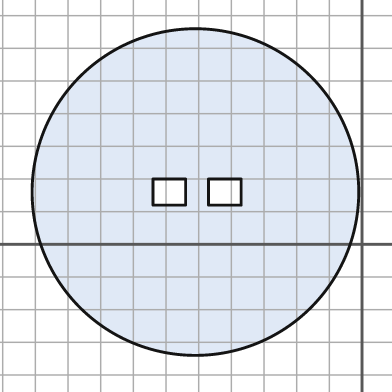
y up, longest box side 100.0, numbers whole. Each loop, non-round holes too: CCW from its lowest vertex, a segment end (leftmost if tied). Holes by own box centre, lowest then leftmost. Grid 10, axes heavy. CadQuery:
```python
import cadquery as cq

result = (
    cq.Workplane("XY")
    .moveTo(-51.0, 16.0)
    .circle(50.0)
    .moveTo(-64.0, 12.0)
    .lineTo(-54.0, 12.0)
    .lineTo(-54.0, 20.0)
    .lineTo(-64.0, 20.0)
    .close()
    .moveTo(-47.0, 12.0)
    .lineTo(-37.0, 12.0)
    .lineTo(-37.0, 20.0)
    .lineTo(-47.0, 20.0)
    .close()
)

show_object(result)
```